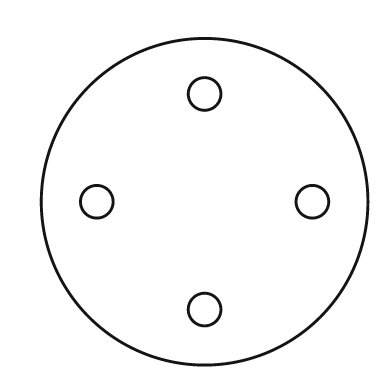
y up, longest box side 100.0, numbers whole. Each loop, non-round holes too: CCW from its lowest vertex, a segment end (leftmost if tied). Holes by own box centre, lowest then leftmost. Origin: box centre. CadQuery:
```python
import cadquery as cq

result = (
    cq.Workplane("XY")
    .moveTo(0.0, 0.0)
    .circle(50.0)
    .moveTo(0.0, -33.0)
    .circle(5.0)
    .moveTo(-33.0, 0.0)
    .circle(5.0)
    .moveTo(33.0, 0.0)
    .circle(5.0)
    .moveTo(0.0, 33.0)
    .circle(5.0)
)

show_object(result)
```